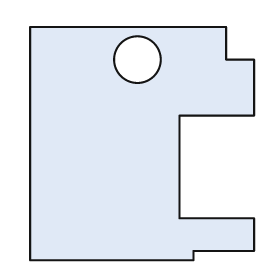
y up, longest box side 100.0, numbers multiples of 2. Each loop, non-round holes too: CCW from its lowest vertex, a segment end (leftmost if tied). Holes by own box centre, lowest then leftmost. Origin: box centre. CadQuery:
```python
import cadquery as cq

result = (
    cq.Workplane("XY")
    .moveTo(-48.0, -50.0)
    .lineTo(22.0, -50.0)
    .lineTo(22.0, -46.0)
    .lineTo(48.0, -46.0)
    .lineTo(48.0, -32.0)
    .lineTo(16.0, -32.0)
    .lineTo(16.0, 12.0)
    .lineTo(48.0, 12.0)
    .lineTo(48.0, 36.0)
    .lineTo(36.0, 36.0)
    .lineTo(36.0, 50.0)
    .lineTo(-48.0, 50.0)
    .close()
    .moveTo(-2.0, 36.0)
    .circle(10.0)
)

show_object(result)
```